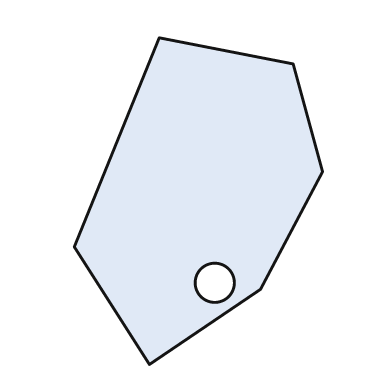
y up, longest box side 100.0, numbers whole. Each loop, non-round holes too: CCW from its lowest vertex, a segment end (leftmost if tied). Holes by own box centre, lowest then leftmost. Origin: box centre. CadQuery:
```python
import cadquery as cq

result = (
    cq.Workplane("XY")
    .moveTo(-15.0, -50.0)
    .lineTo(19.0, -27.0)
    .lineTo(38.0, 9.0)
    .lineTo(29.0, 42.0)
    .lineTo(-12.0, 50.0)
    .lineTo(-38.0, -14.0)
    .close()
    .moveTo(5.0, -25.0)
    .circle(6.0)
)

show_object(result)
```